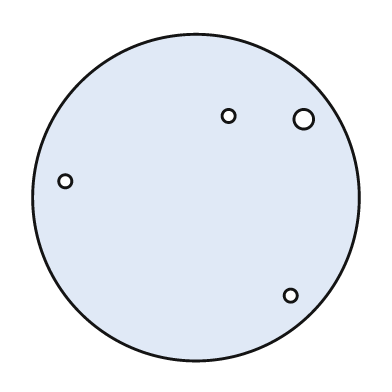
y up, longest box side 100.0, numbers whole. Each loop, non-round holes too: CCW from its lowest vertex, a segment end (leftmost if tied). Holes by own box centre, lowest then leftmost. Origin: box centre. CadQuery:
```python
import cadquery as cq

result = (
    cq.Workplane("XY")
    .moveTo(0.0, 0.0)
    .circle(50.0)
    .moveTo(29.0, -30.0)
    .circle(2.0)
    .moveTo(-40.0, 5.0)
    .circle(2.0)
    .moveTo(33.0, 24.0)
    .circle(3.0)
    .moveTo(10.0, 25.0)
    .circle(2.0)
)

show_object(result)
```